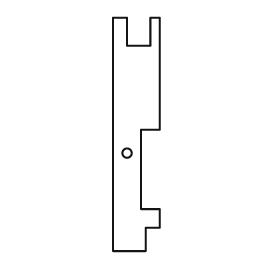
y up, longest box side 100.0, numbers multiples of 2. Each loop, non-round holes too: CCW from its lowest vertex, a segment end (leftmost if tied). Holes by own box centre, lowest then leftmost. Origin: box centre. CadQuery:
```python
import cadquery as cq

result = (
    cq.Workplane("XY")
    .moveTo(-10.0, -50.0)
    .lineTo(4.0, -50.0)
    .lineTo(4.0, -40.0)
    .lineTo(10.0, -40.0)
    .lineTo(10.0, -32.0)
    .lineTo(2.0, -32.0)
    .lineTo(2.0, 2.0)
    .lineTo(10.0, 2.0)
    .lineTo(10.0, 50.0)
    .lineTo(6.0, 50.0)
    .lineTo(6.0, 38.0)
    .lineTo(-4.0, 38.0)
    .lineTo(-4.0, 50.0)
    .lineTo(-10.0, 50.0)
    .close()
    .moveTo(-4.0, -8.0)
    .circle(2.0)
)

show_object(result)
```